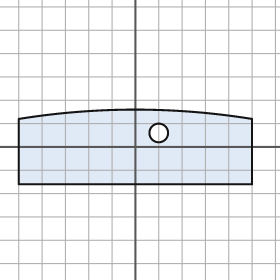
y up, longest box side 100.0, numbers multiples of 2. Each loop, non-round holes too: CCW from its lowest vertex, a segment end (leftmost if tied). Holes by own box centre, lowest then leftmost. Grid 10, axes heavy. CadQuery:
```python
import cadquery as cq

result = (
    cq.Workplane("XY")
    .moveTo(-50.0, -16.0)
    .lineTo(50.0, -16.0)
    .lineTo(50.0, 12.0)
    .threePointArc((0.0, 16.0), (-50.0, 12.0))
    .close()
    .moveTo(10.0, 6.0)
    .circle(4.0)
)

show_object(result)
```